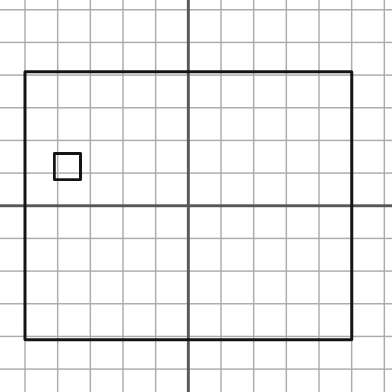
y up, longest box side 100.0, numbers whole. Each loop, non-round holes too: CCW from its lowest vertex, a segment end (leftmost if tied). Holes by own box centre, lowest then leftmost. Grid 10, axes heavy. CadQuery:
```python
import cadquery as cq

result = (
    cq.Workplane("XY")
    .moveTo(-50.0, -41.0)
    .lineTo(50.0, -41.0)
    .lineTo(50.0, 41.0)
    .lineTo(-50.0, 41.0)
    .close()
    .moveTo(-41.0, 8.0)
    .lineTo(-33.0, 8.0)
    .lineTo(-33.0, 16.0)
    .lineTo(-41.0, 16.0)
    .close()
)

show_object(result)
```